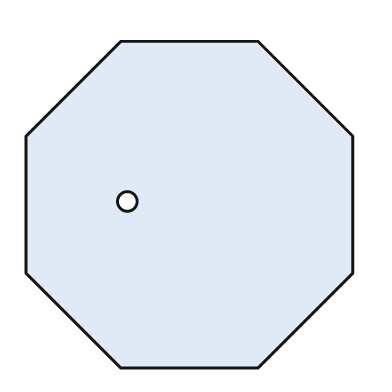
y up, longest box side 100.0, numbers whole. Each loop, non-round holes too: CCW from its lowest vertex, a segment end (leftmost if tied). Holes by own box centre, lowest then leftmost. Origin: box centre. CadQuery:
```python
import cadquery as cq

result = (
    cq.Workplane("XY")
    .moveTo(-21.0, -50.0)
    .lineTo(21.0, -50.0)
    .lineTo(50.0, -21.0)
    .lineTo(50.0, 21.0)
    .lineTo(21.0, 50.0)
    .lineTo(-21.0, 50.0)
    .lineTo(-50.0, 21.0)
    .lineTo(-50.0, -21.0)
    .close()
    .moveTo(-19.0, 1.0)
    .circle(3.0)
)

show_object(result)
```